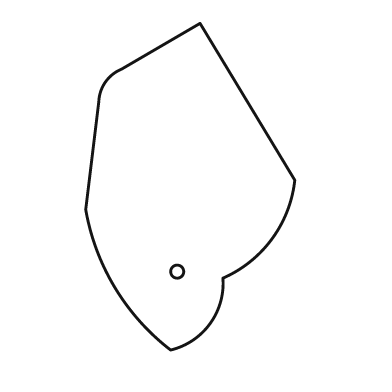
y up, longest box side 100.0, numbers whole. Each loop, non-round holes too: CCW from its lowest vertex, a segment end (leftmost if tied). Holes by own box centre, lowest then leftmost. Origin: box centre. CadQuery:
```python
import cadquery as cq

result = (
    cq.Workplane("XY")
    .moveTo(-6.0, -50.0)
    .threePointArc((6.0, -42.0), (10.0, -28.0))
    .threePointArc((25.0, -16.0), (32.0, 2.0))
    .lineTo(3.0, 50.0)
    .lineTo(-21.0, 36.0)
    .threePointArc((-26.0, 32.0), (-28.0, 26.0))
    .lineTo(-32.0, -7.0)
    .threePointArc((-23.0, -31.0), (-6.0, -50.0))
    .close()
    .moveTo(-4.0, -26.0)
    .circle(2.0)
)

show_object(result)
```